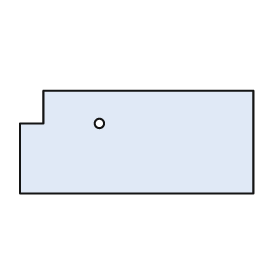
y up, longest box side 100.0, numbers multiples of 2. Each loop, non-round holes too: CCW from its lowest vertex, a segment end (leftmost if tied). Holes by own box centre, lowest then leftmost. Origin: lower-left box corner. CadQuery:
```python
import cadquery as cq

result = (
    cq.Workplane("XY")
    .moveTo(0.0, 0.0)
    .lineTo(100.0, 0.0)
    .lineTo(100.0, 44.0)
    .lineTo(10.0, 44.0)
    .lineTo(10.0, 30.0)
    .lineTo(0.0, 30.0)
    .close()
    .moveTo(34.0, 30.0)
    .circle(2.0)
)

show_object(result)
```